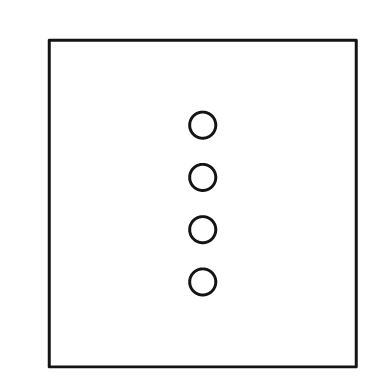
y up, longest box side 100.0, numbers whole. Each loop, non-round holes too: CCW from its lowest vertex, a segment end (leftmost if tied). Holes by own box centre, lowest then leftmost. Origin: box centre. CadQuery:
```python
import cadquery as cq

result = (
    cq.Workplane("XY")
    .moveTo(-47.0, -50.0)
    .lineTo(47.0, -50.0)
    .lineTo(47.0, 50.0)
    .lineTo(-47.0, 50.0)
    .close()
    .moveTo(0.0, -24.0)
    .circle(4.0)
    .moveTo(0.0, -8.0)
    .circle(4.0)
    .moveTo(0.0, 8.0)
    .circle(4.0)
    .moveTo(0.0, 24.0)
    .circle(4.0)
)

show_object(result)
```